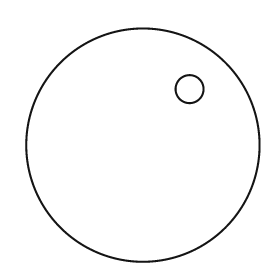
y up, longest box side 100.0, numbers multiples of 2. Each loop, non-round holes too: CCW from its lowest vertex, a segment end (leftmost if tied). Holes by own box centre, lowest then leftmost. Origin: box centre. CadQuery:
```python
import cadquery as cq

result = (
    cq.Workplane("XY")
    .moveTo(0.0, 0.0)
    .circle(50.0)
    .moveTo(20.0, 24.0)
    .circle(6.0)
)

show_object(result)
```